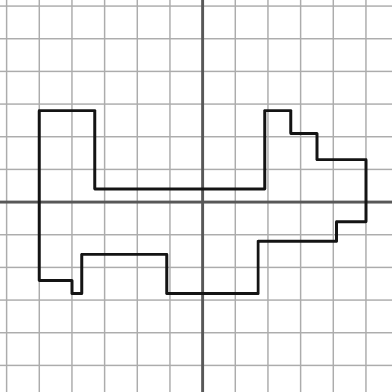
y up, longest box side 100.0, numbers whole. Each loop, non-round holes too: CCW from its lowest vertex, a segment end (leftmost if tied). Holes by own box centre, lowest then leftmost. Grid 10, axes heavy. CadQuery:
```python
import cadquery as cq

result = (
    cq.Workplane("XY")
    .moveTo(-40.0, -28.0)
    .lineTo(-37.0, -28.0)
    .lineTo(-37.0, -16.0)
    .lineTo(-11.0, -16.0)
    .lineTo(-11.0, -28.0)
    .lineTo(17.0, -28.0)
    .lineTo(17.0, -12.0)
    .lineTo(41.0, -12.0)
    .lineTo(41.0, -6.0)
    .lineTo(50.0, -6.0)
    .lineTo(50.0, 13.0)
    .lineTo(35.0, 13.0)
    .lineTo(35.0, 21.0)
    .lineTo(27.0, 21.0)
    .lineTo(27.0, 28.0)
    .lineTo(19.0, 28.0)
    .lineTo(19.0, 4.0)
    .lineTo(-33.0, 4.0)
    .lineTo(-33.0, 28.0)
    .lineTo(-50.0, 28.0)
    .lineTo(-50.0, -24.0)
    .lineTo(-40.0, -24.0)
    .close()
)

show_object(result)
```